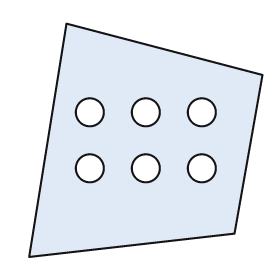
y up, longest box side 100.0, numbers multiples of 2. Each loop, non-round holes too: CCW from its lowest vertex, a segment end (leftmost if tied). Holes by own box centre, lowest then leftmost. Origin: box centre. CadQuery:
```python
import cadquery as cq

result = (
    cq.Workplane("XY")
    .moveTo(-50.0, -50.0)
    .lineTo(38.0, -40.0)
    .lineTo(50.0, 28.0)
    .lineTo(-34.0, 50.0)
    .close()
    .moveTo(-24.0, -12.0)
    .circle(6.0)
    .moveTo(0.0, -12.0)
    .circle(6.0)
    .moveTo(24.0, -12.0)
    .circle(6.0)
    .moveTo(-24.0, 12.0)
    .circle(6.0)
    .moveTo(0.0, 12.0)
    .circle(6.0)
    .moveTo(24.0, 12.0)
    .circle(6.0)
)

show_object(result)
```